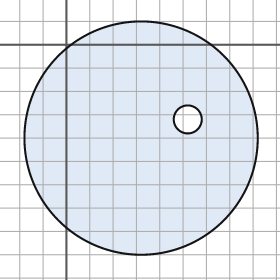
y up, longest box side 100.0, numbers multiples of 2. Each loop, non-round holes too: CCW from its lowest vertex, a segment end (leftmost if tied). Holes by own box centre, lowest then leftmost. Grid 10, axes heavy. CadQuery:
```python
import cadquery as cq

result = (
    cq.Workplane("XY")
    .moveTo(32.0, -40.0)
    .circle(50.0)
    .moveTo(52.0, -32.0)
    .circle(6.0)
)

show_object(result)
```